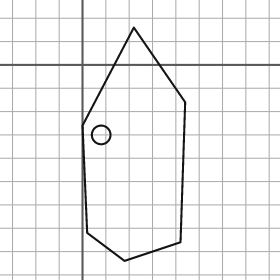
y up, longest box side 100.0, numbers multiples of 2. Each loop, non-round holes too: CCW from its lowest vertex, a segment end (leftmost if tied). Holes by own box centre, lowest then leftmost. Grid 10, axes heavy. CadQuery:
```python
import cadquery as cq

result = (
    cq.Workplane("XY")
    .moveTo(18.0, -84.0)
    .lineTo(42.0, -76.0)
    .lineTo(44.0, -16.0)
    .lineTo(22.0, 16.0)
    .lineTo(0.0, -26.0)
    .lineTo(2.0, -72.0)
    .close()
    .moveTo(8.0, -30.0)
    .circle(4.0)
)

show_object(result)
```